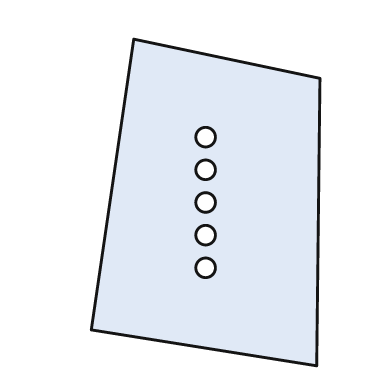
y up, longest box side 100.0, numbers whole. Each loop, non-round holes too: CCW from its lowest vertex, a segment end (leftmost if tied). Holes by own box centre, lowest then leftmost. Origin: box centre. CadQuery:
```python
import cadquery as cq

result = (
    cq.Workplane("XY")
    .moveTo(34.0, -50.0)
    .lineTo(35.0, 38.0)
    .lineTo(-22.0, 50.0)
    .lineTo(-35.0, -39.0)
    .close()
    .moveTo(0.0, -20.0)
    .circle(3.0)
    .moveTo(0.0, -10.0)
    .circle(3.0)
    .moveTo(0.0, 0.0)
    .circle(3.0)
    .moveTo(0.0, 10.0)
    .circle(3.0)
    .moveTo(0.0, 20.0)
    .circle(3.0)
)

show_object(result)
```